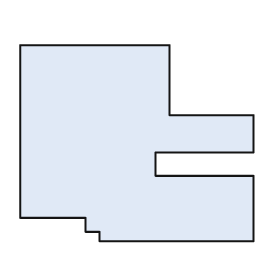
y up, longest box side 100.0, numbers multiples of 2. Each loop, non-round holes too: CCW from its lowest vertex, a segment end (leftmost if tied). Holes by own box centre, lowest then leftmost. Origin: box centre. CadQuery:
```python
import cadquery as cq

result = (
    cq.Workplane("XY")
    .moveTo(-16.0, -42.0)
    .lineTo(50.0, -42.0)
    .lineTo(50.0, -14.0)
    .lineTo(8.0, -14.0)
    .lineTo(8.0, -4.0)
    .lineTo(50.0, -4.0)
    .lineTo(50.0, 12.0)
    .lineTo(14.0, 12.0)
    .lineTo(14.0, 42.0)
    .lineTo(-50.0, 42.0)
    .lineTo(-50.0, -32.0)
    .lineTo(-22.0, -32.0)
    .lineTo(-22.0, -38.0)
    .lineTo(-16.0, -38.0)
    .close()
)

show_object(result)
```